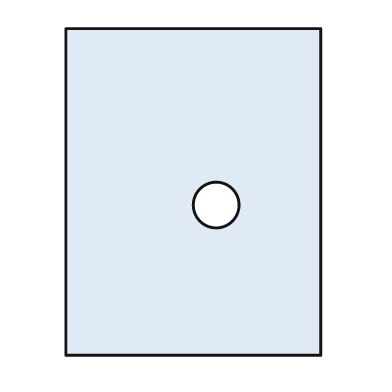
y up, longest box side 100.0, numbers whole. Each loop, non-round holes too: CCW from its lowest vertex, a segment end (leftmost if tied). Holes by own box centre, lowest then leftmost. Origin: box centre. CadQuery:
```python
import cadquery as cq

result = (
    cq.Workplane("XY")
    .moveTo(-39.0, -50.0)
    .lineTo(39.0, -50.0)
    .lineTo(39.0, 50.0)
    .lineTo(-39.0, 50.0)
    .close()
    .moveTo(7.0, -4.0)
    .circle(7.0)
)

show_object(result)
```